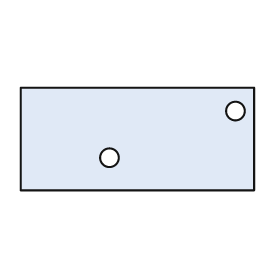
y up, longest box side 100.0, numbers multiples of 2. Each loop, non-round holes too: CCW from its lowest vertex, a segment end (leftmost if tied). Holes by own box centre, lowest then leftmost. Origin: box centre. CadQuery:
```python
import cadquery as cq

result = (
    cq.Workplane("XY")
    .moveTo(-50.0, -22.0)
    .lineTo(50.0, -22.0)
    .lineTo(50.0, 22.0)
    .lineTo(-50.0, 22.0)
    .close()
    .moveTo(-12.0, -8.0)
    .circle(4.0)
    .moveTo(42.0, 12.0)
    .circle(4.0)
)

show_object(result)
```